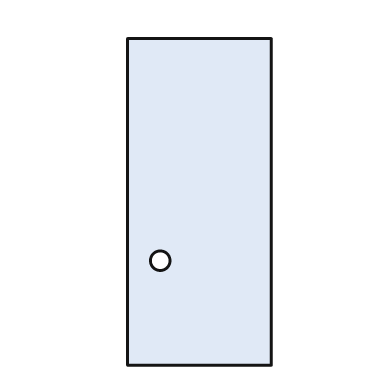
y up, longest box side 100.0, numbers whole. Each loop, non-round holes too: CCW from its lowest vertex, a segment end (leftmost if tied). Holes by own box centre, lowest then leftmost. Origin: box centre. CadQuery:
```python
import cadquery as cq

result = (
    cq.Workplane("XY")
    .moveTo(-22.0, -50.0)
    .lineTo(22.0, -50.0)
    .lineTo(22.0, 50.0)
    .lineTo(-22.0, 50.0)
    .close()
    .moveTo(-12.0, -18.0)
    .circle(3.0)
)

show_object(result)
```